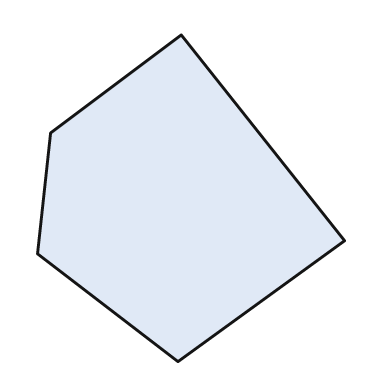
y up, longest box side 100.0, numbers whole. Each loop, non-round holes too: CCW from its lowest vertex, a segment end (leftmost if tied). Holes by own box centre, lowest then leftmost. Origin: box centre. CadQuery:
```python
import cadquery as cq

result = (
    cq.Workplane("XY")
    .moveTo(-4.0, -50.0)
    .lineTo(47.0, -13.0)
    .lineTo(-3.0, 50.0)
    .lineTo(-43.0, 20.0)
    .lineTo(-47.0, -17.0)
    .close()
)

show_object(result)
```